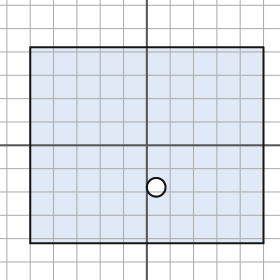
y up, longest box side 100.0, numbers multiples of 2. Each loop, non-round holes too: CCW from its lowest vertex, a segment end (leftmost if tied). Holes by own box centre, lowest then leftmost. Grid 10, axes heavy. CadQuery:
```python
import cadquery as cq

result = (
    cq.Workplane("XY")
    .moveTo(-50.0, -42.0)
    .lineTo(50.0, -42.0)
    .lineTo(50.0, 42.0)
    .lineTo(-50.0, 42.0)
    .close()
    .moveTo(4.0, -18.0)
    .circle(4.0)
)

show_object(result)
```